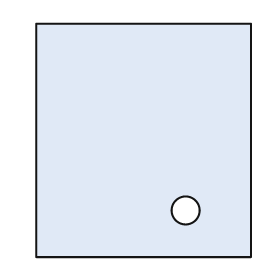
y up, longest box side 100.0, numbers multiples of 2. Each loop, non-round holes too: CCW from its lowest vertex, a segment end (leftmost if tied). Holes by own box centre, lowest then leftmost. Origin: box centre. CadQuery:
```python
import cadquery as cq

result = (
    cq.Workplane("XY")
    .moveTo(-46.0, -50.0)
    .lineTo(46.0, -50.0)
    .lineTo(46.0, 50.0)
    .lineTo(-46.0, 50.0)
    .close()
    .moveTo(18.0, -30.0)
    .circle(6.0)
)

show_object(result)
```